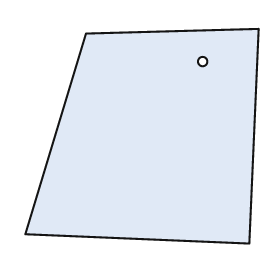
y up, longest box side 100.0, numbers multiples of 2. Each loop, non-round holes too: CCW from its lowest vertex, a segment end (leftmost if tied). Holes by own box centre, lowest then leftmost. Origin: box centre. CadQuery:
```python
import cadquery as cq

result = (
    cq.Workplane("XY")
    .moveTo(46.0, -46.0)
    .lineTo(50.0, 46.0)
    .lineTo(-24.0, 44.0)
    .lineTo(-50.0, -42.0)
    .close()
    .moveTo(26.0, 32.0)
    .circle(2.0)
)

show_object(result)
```